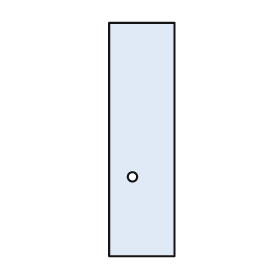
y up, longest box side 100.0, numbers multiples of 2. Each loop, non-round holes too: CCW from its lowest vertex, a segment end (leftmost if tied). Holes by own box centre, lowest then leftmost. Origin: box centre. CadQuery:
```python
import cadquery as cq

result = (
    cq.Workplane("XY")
    .moveTo(-14.0, -50.0)
    .lineTo(14.0, -50.0)
    .lineTo(14.0, 50.0)
    .lineTo(-14.0, 50.0)
    .close()
    .moveTo(-4.0, -16.0)
    .circle(2.0)
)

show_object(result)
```